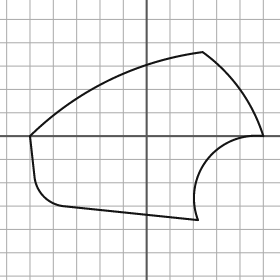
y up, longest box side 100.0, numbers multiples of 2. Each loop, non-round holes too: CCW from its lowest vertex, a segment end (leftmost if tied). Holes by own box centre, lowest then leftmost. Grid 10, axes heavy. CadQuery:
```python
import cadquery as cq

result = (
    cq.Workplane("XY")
    .moveTo(22.0, -36.0)
    .threePointArc((26.0, -10.0), (50.0, 0.0))
    .threePointArc((40.0, 20.0), (24.0, 36.0))
    .threePointArc((-16.0, 24.0), (-50.0, 0.0))
    .lineTo(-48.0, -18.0)
    .threePointArc((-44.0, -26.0), (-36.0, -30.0))
    .close()
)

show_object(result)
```